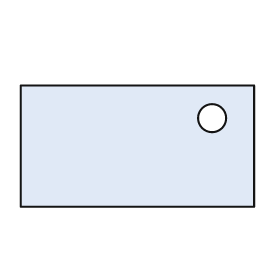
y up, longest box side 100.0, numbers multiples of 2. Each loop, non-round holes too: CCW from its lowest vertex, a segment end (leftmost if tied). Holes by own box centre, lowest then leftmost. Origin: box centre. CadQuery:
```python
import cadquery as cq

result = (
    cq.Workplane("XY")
    .moveTo(-50.0, -26.0)
    .lineTo(50.0, -26.0)
    .lineTo(50.0, 26.0)
    .lineTo(-50.0, 26.0)
    .close()
    .moveTo(32.0, 12.0)
    .circle(6.0)
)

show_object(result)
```